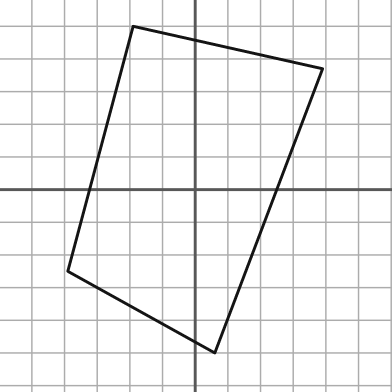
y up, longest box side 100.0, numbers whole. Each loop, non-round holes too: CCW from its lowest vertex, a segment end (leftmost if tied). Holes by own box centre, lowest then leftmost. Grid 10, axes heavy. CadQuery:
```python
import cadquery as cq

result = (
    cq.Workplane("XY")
    .moveTo(6.0, -50.0)
    .lineTo(39.0, 37.0)
    .lineTo(-19.0, 50.0)
    .lineTo(-39.0, -25.0)
    .close()
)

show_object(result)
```